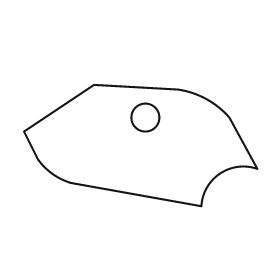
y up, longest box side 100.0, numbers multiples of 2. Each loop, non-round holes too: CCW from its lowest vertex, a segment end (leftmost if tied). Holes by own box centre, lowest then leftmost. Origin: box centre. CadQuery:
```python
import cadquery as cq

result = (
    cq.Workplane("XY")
    .moveTo(26.0, -26.0)
    .threePointArc((34.0, -12.0), (50.0, -10.0))
    .lineTo(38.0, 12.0)
    .threePointArc((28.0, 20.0), (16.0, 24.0))
    .lineTo(-20.0, 26.0)
    .lineTo(-50.0, 6.0)
    .lineTo(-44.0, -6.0)
    .threePointArc((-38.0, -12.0), (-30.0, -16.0))
    .close()
    .moveTo(2.0, 12.0)
    .circle(6.0)
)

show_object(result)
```